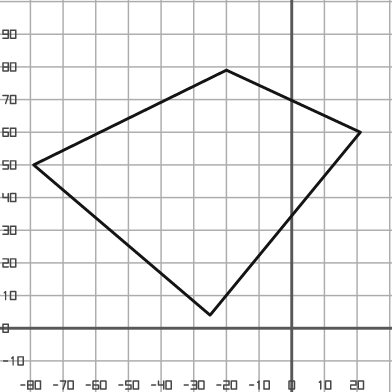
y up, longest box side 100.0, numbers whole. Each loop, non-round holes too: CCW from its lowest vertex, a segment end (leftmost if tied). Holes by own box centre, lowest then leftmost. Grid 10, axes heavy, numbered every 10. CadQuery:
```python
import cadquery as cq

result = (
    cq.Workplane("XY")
    .moveTo(-25.0, 4.0)
    .lineTo(21.0, 60.0)
    .lineTo(-20.0, 79.0)
    .lineTo(-79.0, 50.0)
    .close()
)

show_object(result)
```